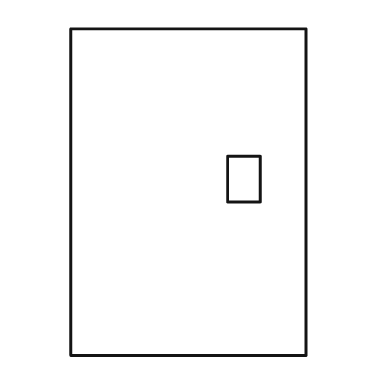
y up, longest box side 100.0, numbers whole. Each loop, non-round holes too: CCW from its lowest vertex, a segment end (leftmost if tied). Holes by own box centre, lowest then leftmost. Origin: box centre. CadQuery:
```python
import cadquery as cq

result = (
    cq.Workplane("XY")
    .moveTo(-36.0, -50.0)
    .lineTo(36.0, -50.0)
    .lineTo(36.0, 50.0)
    .lineTo(-36.0, 50.0)
    .close()
    .moveTo(12.0, -3.0)
    .lineTo(22.0, -3.0)
    .lineTo(22.0, 11.0)
    .lineTo(12.0, 11.0)
    .close()
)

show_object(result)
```